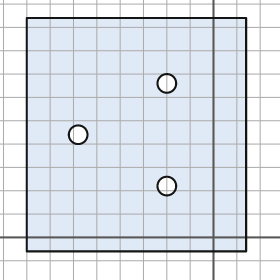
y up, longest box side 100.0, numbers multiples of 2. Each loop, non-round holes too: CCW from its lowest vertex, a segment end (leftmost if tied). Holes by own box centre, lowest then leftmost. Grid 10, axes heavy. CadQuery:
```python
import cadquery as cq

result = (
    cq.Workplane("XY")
    .moveTo(-80.0, -6.0)
    .lineTo(14.0, -6.0)
    .lineTo(14.0, 94.0)
    .lineTo(-80.0, 94.0)
    .close()
    .moveTo(-20.0, 22.0)
    .circle(4.0)
    .moveTo(-58.0, 44.0)
    .circle(4.0)
    .moveTo(-20.0, 66.0)
    .circle(4.0)
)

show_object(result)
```